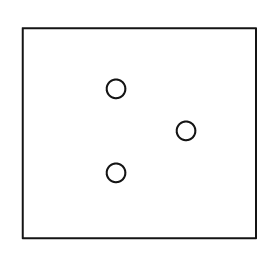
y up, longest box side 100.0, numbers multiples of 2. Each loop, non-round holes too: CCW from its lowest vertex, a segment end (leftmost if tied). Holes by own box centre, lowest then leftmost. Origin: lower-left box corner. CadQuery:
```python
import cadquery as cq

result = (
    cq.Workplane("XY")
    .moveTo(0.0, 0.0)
    .lineTo(100.0, 0.0)
    .lineTo(100.0, 90.0)
    .lineTo(0.0, 90.0)
    .close()
    .moveTo(40.0, 28.0)
    .circle(4.0)
    .moveTo(70.0, 46.0)
    .circle(4.0)
    .moveTo(40.0, 64.0)
    .circle(4.0)
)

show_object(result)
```